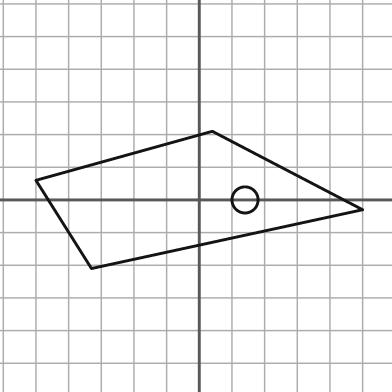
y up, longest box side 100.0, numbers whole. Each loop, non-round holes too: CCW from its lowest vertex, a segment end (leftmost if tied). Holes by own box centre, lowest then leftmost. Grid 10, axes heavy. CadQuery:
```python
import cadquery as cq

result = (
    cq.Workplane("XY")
    .moveTo(-33.0, -21.0)
    .lineTo(50.0, -3.0)
    .lineTo(4.0, 21.0)
    .lineTo(-50.0, 6.0)
    .close()
    .moveTo(14.0, 0.0)
    .circle(4.0)
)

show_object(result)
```